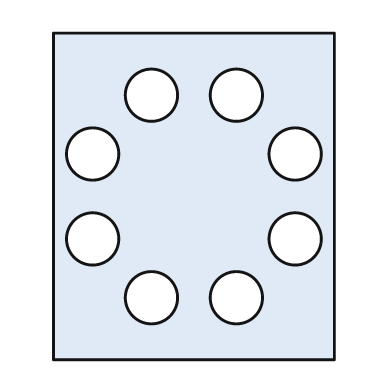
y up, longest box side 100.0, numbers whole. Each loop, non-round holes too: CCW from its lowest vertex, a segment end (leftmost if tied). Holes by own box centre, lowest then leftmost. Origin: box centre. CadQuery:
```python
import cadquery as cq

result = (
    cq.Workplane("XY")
    .moveTo(-43.0, -50.0)
    .lineTo(43.0, -50.0)
    .lineTo(43.0, 50.0)
    .lineTo(-43.0, 50.0)
    .close()
    .moveTo(-13.0, -31.0)
    .circle(8.0)
    .moveTo(13.0, -31.0)
    .circle(8.0)
    .moveTo(-31.0, -13.0)
    .circle(8.0)
    .moveTo(31.0, -13.0)
    .circle(8.0)
    .moveTo(-31.0, 13.0)
    .circle(8.0)
    .moveTo(31.0, 13.0)
    .circle(8.0)
    .moveTo(-13.0, 31.0)
    .circle(8.0)
    .moveTo(13.0, 31.0)
    .circle(8.0)
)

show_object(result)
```